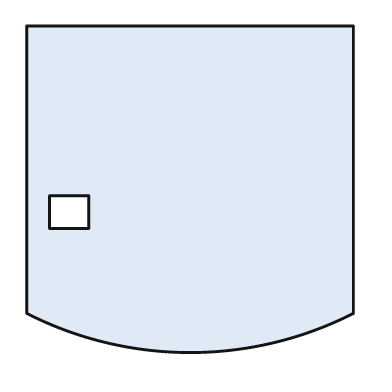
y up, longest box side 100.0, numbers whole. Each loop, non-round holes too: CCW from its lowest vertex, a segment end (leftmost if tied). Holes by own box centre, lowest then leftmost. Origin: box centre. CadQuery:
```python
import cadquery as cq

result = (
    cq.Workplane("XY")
    .moveTo(-50.0, -38.0)
    .threePointArc((0.0, -50.0), (50.0, -38.0))
    .lineTo(50.0, 50.0)
    .lineTo(-50.0, 50.0)
    .close()
    .moveTo(-43.0, -12.0)
    .lineTo(-31.0, -12.0)
    .lineTo(-31.0, -2.0)
    .lineTo(-43.0, -2.0)
    .close()
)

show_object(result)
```